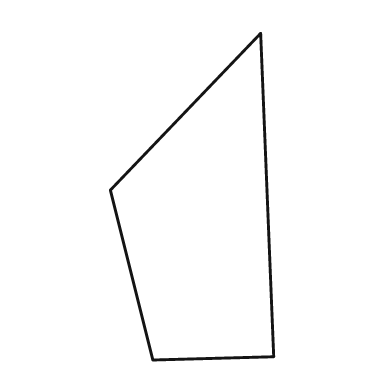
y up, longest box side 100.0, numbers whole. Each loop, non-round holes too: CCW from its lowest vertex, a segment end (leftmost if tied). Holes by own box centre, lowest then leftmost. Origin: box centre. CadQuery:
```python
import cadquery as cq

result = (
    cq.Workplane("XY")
    .moveTo(-12.0, -50.0)
    .lineTo(25.0, -49.0)
    .lineTo(21.0, 50.0)
    .lineTo(-25.0, 2.0)
    .close()
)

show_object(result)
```